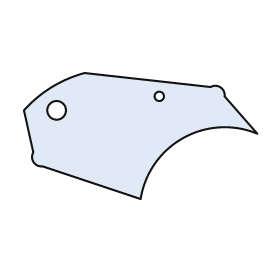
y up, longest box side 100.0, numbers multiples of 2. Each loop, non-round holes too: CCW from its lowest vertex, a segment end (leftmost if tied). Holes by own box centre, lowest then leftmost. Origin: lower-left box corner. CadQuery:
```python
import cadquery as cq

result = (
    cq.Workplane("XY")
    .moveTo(50.0, 0.0)
    .threePointArc((68.0, 26.0), (100.0, 28.0))
    .lineTo(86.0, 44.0)
    .threePointArc((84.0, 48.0), (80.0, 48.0))
    .lineTo(26.0, 54.0)
    .threePointArc((12.0, 48.0), (0.0, 38.0))
    .lineTo(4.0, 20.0)
    .threePointArc((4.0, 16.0), (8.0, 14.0))
    .close()
    .moveTo(14.0, 38.0)
    .circle(4.0)
    .moveTo(58.0, 44.0)
    .circle(2.0)
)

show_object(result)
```